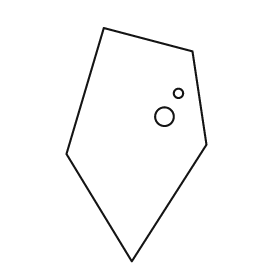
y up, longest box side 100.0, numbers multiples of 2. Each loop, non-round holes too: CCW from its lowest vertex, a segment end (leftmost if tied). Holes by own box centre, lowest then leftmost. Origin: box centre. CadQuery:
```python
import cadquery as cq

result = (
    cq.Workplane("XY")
    .moveTo(-2.0, -50.0)
    .lineTo(30.0, 0.0)
    .lineTo(24.0, 40.0)
    .lineTo(-14.0, 50.0)
    .lineTo(-30.0, -4.0)
    .close()
    .moveTo(12.0, 12.0)
    .circle(4.0)
    .moveTo(18.0, 22.0)
    .circle(2.0)
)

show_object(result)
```